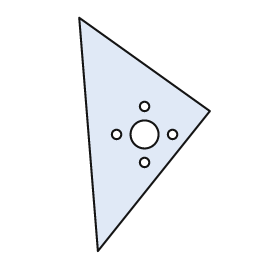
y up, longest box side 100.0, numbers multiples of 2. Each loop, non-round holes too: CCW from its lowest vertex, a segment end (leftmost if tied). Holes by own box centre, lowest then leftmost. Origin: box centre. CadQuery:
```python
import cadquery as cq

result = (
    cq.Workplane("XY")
    .moveTo(-20.0, -50.0)
    .lineTo(28.0, 10.0)
    .lineTo(-28.0, 50.0)
    .close()
    .moveTo(0.0, -12.0)
    .circle(2.0)
    .moveTo(-12.0, 0.0)
    .circle(2.0)
    .moveTo(0.0, 0.0)
    .circle(6.0)
    .moveTo(12.0, 0.0)
    .circle(2.0)
    .moveTo(0.0, 12.0)
    .circle(2.0)
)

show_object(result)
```